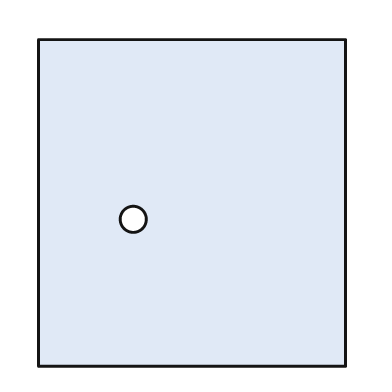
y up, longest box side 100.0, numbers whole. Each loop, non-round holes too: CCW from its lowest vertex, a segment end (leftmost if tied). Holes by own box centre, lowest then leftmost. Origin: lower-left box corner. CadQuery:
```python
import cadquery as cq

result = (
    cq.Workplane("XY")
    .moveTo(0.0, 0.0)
    .lineTo(94.0, 0.0)
    .lineTo(94.0, 100.0)
    .lineTo(0.0, 100.0)
    .close()
    .moveTo(29.0, 45.0)
    .circle(4.0)
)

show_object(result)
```